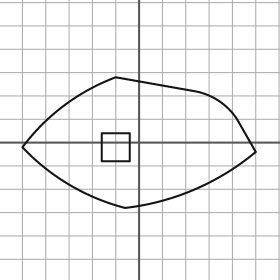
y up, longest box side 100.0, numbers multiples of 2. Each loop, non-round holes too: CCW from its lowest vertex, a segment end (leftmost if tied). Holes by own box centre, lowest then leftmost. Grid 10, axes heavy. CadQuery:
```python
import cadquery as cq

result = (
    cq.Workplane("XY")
    .moveTo(-6.0, -28.0)
    .threePointArc((24.0, -20.0), (50.0, -4.0))
    .lineTo(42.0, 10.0)
    .threePointArc((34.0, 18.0), (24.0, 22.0))
    .lineTo(-10.0, 28.0)
    .threePointArc((-32.0, 16.0), (-50.0, -2.0))
    .threePointArc((-30.0, -18.0), (-6.0, -28.0))
    .close()
    .moveTo(-16.0, -8.0)
    .lineTo(-4.0, -8.0)
    .lineTo(-4.0, 4.0)
    .lineTo(-16.0, 4.0)
    .close()
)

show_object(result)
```